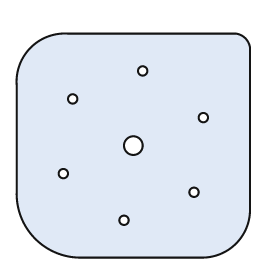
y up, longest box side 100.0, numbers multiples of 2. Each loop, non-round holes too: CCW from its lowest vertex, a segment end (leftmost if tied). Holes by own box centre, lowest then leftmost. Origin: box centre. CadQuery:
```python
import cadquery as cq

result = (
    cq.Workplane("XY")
    .moveTo(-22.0, -48.0)
    .lineTo(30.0, -48.0)
    .threePointArc((44.0, -42.0), (50.0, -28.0))
    .lineTo(50.0, 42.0)
    .threePointArc((48.0, 46.0), (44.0, 48.0))
    .lineTo(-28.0, 48.0)
    .threePointArc((-44.0, 42.0), (-50.0, 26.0))
    .lineTo(-50.0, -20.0)
    .threePointArc((-42.0, -40.0), (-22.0, -48.0))
    .close()
    .moveTo(-4.0, -32.0)
    .circle(2.0)
    .moveTo(26.0, -20.0)
    .circle(2.0)
    .moveTo(-30.0, -12.0)
    .circle(2.0)
    .moveTo(0.0, 0.0)
    .circle(4.0)
    .moveTo(30.0, 12.0)
    .circle(2.0)
    .moveTo(-26.0, 20.0)
    .circle(2.0)
    .moveTo(4.0, 32.0)
    .circle(2.0)
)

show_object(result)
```